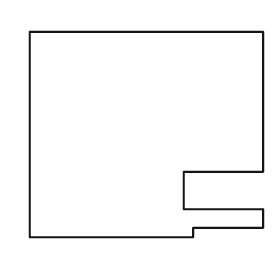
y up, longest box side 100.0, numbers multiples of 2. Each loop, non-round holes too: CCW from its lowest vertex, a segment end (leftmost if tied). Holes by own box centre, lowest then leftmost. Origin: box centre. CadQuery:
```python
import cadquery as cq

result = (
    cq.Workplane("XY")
    .moveTo(-50.0, -44.0)
    .lineTo(20.0, -44.0)
    .lineTo(20.0, -40.0)
    .lineTo(50.0, -40.0)
    .lineTo(50.0, -32.0)
    .lineTo(16.0, -32.0)
    .lineTo(16.0, -16.0)
    .lineTo(50.0, -16.0)
    .lineTo(50.0, 44.0)
    .lineTo(-50.0, 44.0)
    .close()
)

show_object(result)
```